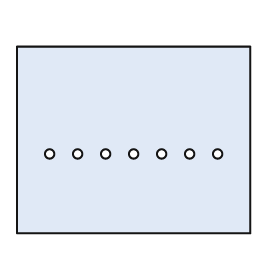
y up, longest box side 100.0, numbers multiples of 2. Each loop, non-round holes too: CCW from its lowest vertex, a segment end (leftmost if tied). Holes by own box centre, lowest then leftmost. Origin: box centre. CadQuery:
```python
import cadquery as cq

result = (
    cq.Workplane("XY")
    .moveTo(-50.0, -40.0)
    .lineTo(50.0, -40.0)
    .lineTo(50.0, 40.0)
    .lineTo(-50.0, 40.0)
    .close()
    .moveTo(-36.0, -6.0)
    .circle(2.0)
    .moveTo(-24.0, -6.0)
    .circle(2.0)
    .moveTo(-12.0, -6.0)
    .circle(2.0)
    .moveTo(0.0, -6.0)
    .circle(2.0)
    .moveTo(12.0, -6.0)
    .circle(2.0)
    .moveTo(24.0, -6.0)
    .circle(2.0)
    .moveTo(36.0, -6.0)
    .circle(2.0)
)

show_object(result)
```